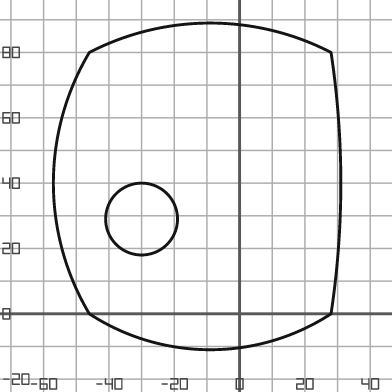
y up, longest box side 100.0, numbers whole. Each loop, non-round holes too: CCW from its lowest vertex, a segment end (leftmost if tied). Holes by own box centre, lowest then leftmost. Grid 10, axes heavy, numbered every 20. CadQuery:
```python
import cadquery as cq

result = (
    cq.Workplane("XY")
    .moveTo(-46.0, 0.0)
    .threePointArc((-9.0, -11.0), (28.0, 0.0))
    .threePointArc((31.0, 40.0), (28.0, 80.0))
    .threePointArc((-9.0, 89.0), (-46.0, 80.0))
    .threePointArc((-57.0, 40.0), (-46.0, 0.0))
    .close()
    .moveTo(-30.0, 29.0)
    .circle(11.0)
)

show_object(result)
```